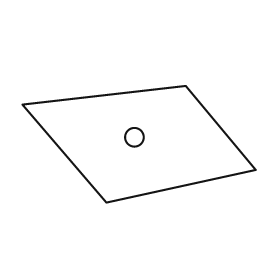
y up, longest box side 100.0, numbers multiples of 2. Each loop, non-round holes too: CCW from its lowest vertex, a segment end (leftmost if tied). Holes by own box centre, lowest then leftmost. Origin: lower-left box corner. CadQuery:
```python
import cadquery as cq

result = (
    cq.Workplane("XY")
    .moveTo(36.0, 0.0)
    .lineTo(100.0, 14.0)
    .lineTo(70.0, 50.0)
    .lineTo(0.0, 42.0)
    .close()
    .moveTo(48.0, 28.0)
    .circle(4.0)
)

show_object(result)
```